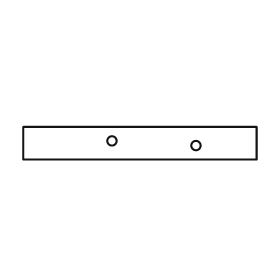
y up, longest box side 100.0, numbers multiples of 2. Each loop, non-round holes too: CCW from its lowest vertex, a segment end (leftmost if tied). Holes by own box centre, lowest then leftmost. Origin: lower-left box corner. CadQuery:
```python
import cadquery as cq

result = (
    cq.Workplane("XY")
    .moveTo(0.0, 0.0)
    .lineTo(100.0, 0.0)
    .lineTo(100.0, 14.0)
    .lineTo(0.0, 14.0)
    .close()
    .moveTo(74.0, 6.0)
    .circle(2.0)
    .moveTo(38.0, 8.0)
    .circle(2.0)
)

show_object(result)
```